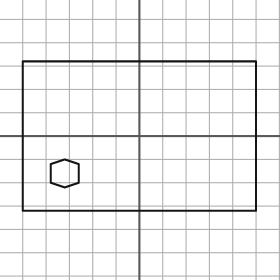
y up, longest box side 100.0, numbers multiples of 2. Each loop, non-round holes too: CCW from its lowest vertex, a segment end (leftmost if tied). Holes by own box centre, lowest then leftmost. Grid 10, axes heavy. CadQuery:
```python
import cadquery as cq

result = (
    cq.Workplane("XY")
    .moveTo(-50.0, -32.0)
    .lineTo(50.0, -32.0)
    .lineTo(50.0, 32.0)
    .lineTo(-50.0, 32.0)
    .close()
    .moveTo(-32.0, -22.0)
    .lineTo(-26.0, -20.0)
    .lineTo(-26.0, -12.0)
    .lineTo(-32.0, -10.0)
    .lineTo(-38.0, -12.0)
    .lineTo(-38.0, -20.0)
    .close()
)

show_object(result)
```